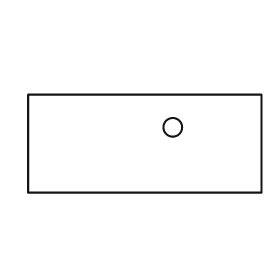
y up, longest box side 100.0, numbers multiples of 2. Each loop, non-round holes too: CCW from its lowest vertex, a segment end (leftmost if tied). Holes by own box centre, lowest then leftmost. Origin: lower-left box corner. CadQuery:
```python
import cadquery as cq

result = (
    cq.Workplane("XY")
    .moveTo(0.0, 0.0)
    .lineTo(100.0, 0.0)
    .lineTo(100.0, 42.0)
    .lineTo(0.0, 42.0)
    .close()
    .moveTo(62.0, 28.0)
    .circle(4.0)
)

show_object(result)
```